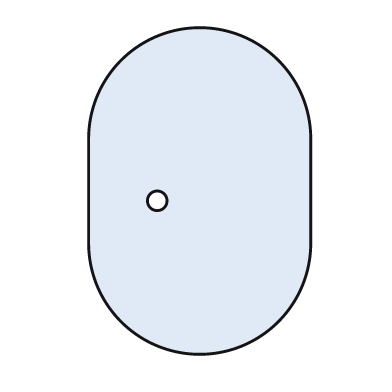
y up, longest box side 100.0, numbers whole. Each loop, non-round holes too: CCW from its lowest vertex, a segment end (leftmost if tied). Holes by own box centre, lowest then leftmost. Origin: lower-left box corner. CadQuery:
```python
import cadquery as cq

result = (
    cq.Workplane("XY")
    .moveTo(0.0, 34.0)
    .threePointArc((34.0, 0.0), (68.0, 34.0))
    .lineTo(68.0, 66.0)
    .threePointArc((34.0, 100.0), (0.0, 66.0))
    .close()
    .moveTo(21.0, 47.0)
    .circle(3.0)
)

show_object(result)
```